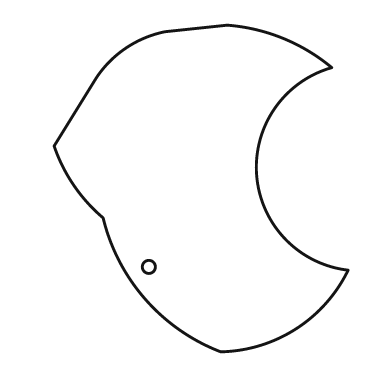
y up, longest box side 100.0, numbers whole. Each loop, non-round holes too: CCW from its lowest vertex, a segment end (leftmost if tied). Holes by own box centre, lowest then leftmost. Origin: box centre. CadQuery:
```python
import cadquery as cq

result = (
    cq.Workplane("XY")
    .moveTo(6.0, -50.0)
    .threePointArc((29.0, -43.0), (45.0, -25.0))
    .threePointArc((17.0, 4.0), (40.0, 37.0))
    .threePointArc((25.0, 46.0), (8.0, 50.0))
    .lineTo(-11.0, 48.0)
    .threePointArc((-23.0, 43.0), (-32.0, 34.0))
    .lineTo(-45.0, 13.0)
    .threePointArc((-39.0, 1.0), (-30.0, -9.0))
    .threePointArc((-17.0, -34.0), (6.0, -50.0))
    .close()
    .moveTo(-16.0, -24.0)
    .circle(2.0)
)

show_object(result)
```